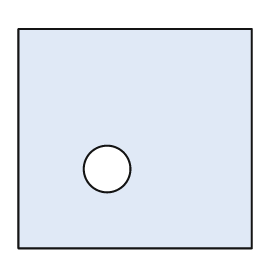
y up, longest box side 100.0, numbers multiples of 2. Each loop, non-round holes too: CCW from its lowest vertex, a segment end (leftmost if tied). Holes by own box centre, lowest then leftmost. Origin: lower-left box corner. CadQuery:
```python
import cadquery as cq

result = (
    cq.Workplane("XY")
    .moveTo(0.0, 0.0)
    .lineTo(100.0, 0.0)
    .lineTo(100.0, 94.0)
    .lineTo(0.0, 94.0)
    .close()
    .moveTo(38.0, 34.0)
    .circle(10.0)
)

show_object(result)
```